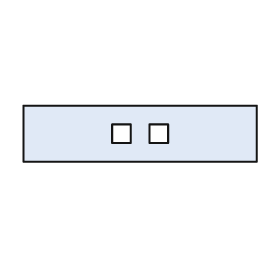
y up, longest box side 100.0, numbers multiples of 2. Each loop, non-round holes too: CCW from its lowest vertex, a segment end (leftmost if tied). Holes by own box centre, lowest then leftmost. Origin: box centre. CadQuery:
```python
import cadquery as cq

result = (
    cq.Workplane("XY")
    .moveTo(-50.0, -12.0)
    .lineTo(50.0, -12.0)
    .lineTo(50.0, 12.0)
    .lineTo(-50.0, 12.0)
    .close()
    .moveTo(-12.0, -4.0)
    .lineTo(-4.0, -4.0)
    .lineTo(-4.0, 4.0)
    .lineTo(-12.0, 4.0)
    .close()
    .moveTo(4.0, -4.0)
    .lineTo(12.0, -4.0)
    .lineTo(12.0, 4.0)
    .lineTo(4.0, 4.0)
    .close()
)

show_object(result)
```